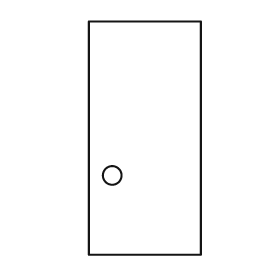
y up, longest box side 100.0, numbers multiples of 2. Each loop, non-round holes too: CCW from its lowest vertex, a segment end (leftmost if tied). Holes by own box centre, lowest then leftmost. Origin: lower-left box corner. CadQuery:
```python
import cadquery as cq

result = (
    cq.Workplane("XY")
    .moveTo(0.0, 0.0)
    .lineTo(48.0, 0.0)
    .lineTo(48.0, 100.0)
    .lineTo(0.0, 100.0)
    .close()
    .moveTo(10.0, 34.0)
    .circle(4.0)
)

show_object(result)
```